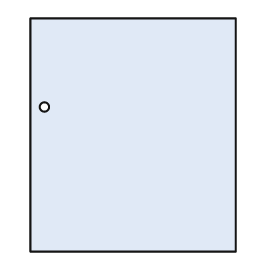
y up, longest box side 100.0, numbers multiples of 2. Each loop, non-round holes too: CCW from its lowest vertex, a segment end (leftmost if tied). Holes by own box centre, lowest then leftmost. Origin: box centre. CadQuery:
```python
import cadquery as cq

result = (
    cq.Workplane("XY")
    .moveTo(-44.0, -50.0)
    .lineTo(44.0, -50.0)
    .lineTo(44.0, 50.0)
    .lineTo(-44.0, 50.0)
    .close()
    .moveTo(-38.0, 12.0)
    .circle(2.0)
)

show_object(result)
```